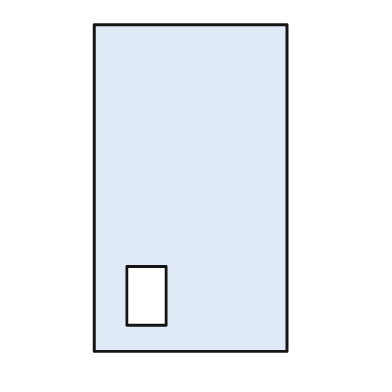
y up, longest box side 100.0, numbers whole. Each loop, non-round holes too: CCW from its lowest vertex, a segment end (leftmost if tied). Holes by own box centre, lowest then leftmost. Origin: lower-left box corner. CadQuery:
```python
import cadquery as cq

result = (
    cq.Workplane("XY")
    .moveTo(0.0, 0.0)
    .lineTo(59.0, 0.0)
    .lineTo(59.0, 100.0)
    .lineTo(0.0, 100.0)
    .close()
    .moveTo(10.0, 8.0)
    .lineTo(22.0, 8.0)
    .lineTo(22.0, 26.0)
    .lineTo(10.0, 26.0)
    .close()
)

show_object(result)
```